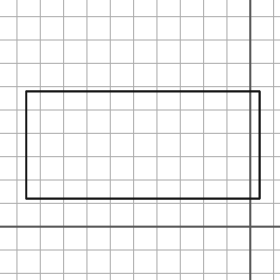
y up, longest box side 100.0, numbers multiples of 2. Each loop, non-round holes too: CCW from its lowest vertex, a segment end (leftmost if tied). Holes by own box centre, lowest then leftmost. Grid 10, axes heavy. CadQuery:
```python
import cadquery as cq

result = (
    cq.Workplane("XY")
    .moveTo(-96.0, 12.0)
    .lineTo(4.0, 12.0)
    .lineTo(4.0, 58.0)
    .lineTo(-96.0, 58.0)
    .close()
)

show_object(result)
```